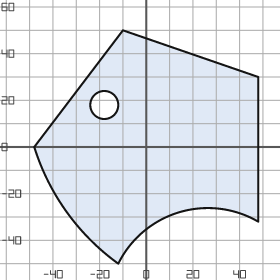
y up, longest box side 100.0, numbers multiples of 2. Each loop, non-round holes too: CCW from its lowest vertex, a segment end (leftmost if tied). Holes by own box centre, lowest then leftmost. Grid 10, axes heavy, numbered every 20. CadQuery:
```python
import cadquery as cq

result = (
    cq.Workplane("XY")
    .moveTo(-12.0, -50.0)
    .threePointArc((14.0, -28.0), (48.0, -32.0))
    .lineTo(48.0, 30.0)
    .lineTo(-10.0, 50.0)
    .lineTo(-48.0, 0.0)
    .threePointArc((-34.0, -28.0), (-12.0, -50.0))
    .close()
    .moveTo(-18.0, 18.0)
    .circle(6.0)
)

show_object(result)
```